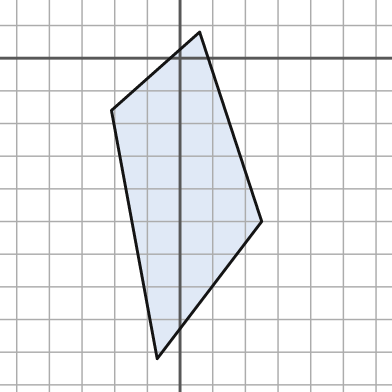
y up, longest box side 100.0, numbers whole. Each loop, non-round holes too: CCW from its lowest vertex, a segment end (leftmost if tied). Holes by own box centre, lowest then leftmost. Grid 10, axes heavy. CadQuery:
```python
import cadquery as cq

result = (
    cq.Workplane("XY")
    .moveTo(-7.0, -92.0)
    .lineTo(25.0, -50.0)
    .lineTo(6.0, 8.0)
    .lineTo(-21.0, -16.0)
    .close()
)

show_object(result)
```